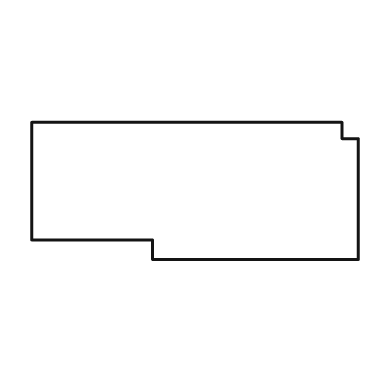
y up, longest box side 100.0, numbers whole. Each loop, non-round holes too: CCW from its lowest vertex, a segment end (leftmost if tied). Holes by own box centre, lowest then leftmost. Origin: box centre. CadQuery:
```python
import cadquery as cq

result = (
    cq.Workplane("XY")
    .moveTo(-13.0, -21.0)
    .lineTo(50.0, -21.0)
    .lineTo(50.0, 16.0)
    .lineTo(45.0, 16.0)
    .lineTo(45.0, 21.0)
    .lineTo(-50.0, 21.0)
    .lineTo(-50.0, -15.0)
    .lineTo(-13.0, -15.0)
    .close()
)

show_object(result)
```